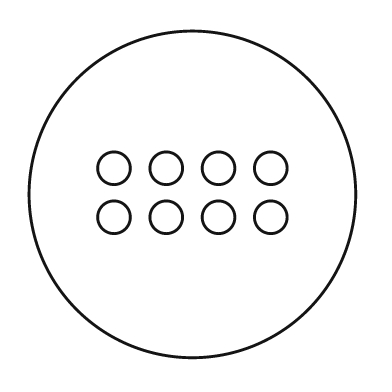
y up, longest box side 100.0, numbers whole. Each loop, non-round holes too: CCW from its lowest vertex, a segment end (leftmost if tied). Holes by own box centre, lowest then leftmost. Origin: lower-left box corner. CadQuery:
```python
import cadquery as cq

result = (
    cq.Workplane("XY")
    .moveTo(50.0, 50.0)
    .circle(50.0)
    .moveTo(26.0, 43.0)
    .circle(5.0)
    .moveTo(42.0, 43.0)
    .circle(5.0)
    .moveTo(58.0, 43.0)
    .circle(5.0)
    .moveTo(74.0, 43.0)
    .circle(5.0)
    .moveTo(26.0, 58.0)
    .circle(5.0)
    .moveTo(42.0, 58.0)
    .circle(5.0)
    .moveTo(58.0, 58.0)
    .circle(5.0)
    .moveTo(74.0, 58.0)
    .circle(5.0)
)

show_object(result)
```